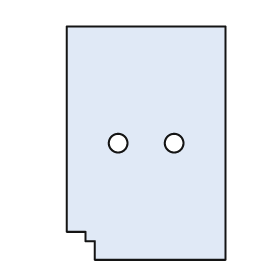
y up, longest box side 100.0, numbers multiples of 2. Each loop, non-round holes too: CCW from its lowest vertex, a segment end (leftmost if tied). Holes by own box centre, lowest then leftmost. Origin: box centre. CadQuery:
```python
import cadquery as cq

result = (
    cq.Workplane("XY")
    .moveTo(-22.0, -50.0)
    .lineTo(34.0, -50.0)
    .lineTo(34.0, 50.0)
    .lineTo(-34.0, 50.0)
    .lineTo(-34.0, -38.0)
    .lineTo(-26.0, -38.0)
    .lineTo(-26.0, -42.0)
    .lineTo(-22.0, -42.0)
    .close()
    .moveTo(-12.0, 0.0)
    .circle(4.0)
    .moveTo(12.0, 0.0)
    .circle(4.0)
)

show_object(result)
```